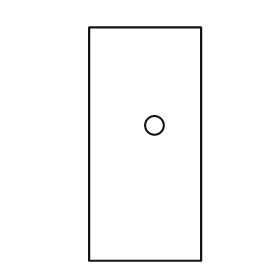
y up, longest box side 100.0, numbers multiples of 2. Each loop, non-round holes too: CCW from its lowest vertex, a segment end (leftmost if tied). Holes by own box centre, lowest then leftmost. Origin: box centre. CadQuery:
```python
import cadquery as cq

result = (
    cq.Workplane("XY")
    .moveTo(-24.0, -50.0)
    .lineTo(24.0, -50.0)
    .lineTo(24.0, 50.0)
    .lineTo(-24.0, 50.0)
    .close()
    .moveTo(4.0, 8.0)
    .circle(4.0)
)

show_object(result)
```